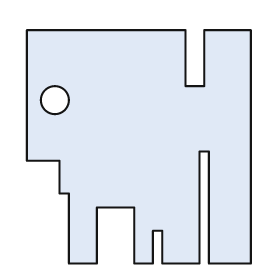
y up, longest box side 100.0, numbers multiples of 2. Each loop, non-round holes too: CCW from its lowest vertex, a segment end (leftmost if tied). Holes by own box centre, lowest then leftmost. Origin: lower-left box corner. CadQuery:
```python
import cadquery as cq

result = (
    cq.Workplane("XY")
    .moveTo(18.0, 0.0)
    .lineTo(30.0, 0.0)
    .lineTo(30.0, 24.0)
    .lineTo(46.0, 24.0)
    .lineTo(46.0, 0.0)
    .lineTo(54.0, 0.0)
    .lineTo(54.0, 14.0)
    .lineTo(58.0, 14.0)
    .lineTo(58.0, 0.0)
    .lineTo(74.0, 0.0)
    .lineTo(74.0, 48.0)
    .lineTo(78.0, 48.0)
    .lineTo(78.0, 0.0)
    .lineTo(96.0, 0.0)
    .lineTo(96.0, 100.0)
    .lineTo(76.0, 100.0)
    .lineTo(76.0, 76.0)
    .lineTo(68.0, 76.0)
    .lineTo(68.0, 100.0)
    .lineTo(0.0, 100.0)
    .lineTo(0.0, 44.0)
    .lineTo(14.0, 44.0)
    .lineTo(14.0, 30.0)
    .lineTo(18.0, 30.0)
    .close()
    .moveTo(12.0, 70.0)
    .circle(6.0)
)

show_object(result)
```